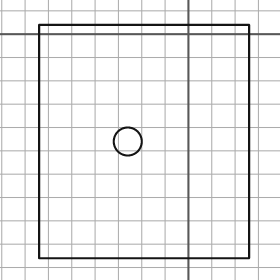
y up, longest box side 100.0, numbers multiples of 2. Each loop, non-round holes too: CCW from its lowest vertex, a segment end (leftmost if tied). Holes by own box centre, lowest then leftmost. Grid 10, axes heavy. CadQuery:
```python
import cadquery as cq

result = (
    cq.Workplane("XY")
    .moveTo(-64.0, -96.0)
    .lineTo(26.0, -96.0)
    .lineTo(26.0, 4.0)
    .lineTo(-64.0, 4.0)
    .close()
    .moveTo(-26.0, -46.0)
    .circle(6.0)
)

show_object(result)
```